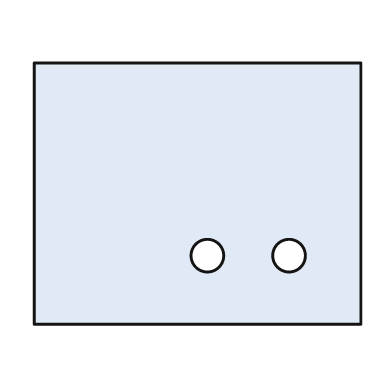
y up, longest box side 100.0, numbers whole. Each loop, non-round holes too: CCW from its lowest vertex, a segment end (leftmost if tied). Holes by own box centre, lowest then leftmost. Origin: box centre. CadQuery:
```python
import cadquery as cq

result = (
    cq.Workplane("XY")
    .moveTo(-50.0, -40.0)
    .lineTo(50.0, -40.0)
    .lineTo(50.0, 40.0)
    .lineTo(-50.0, 40.0)
    .close()
    .moveTo(3.0, -19.0)
    .circle(5.0)
    .moveTo(28.0, -19.0)
    .circle(5.0)
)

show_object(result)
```